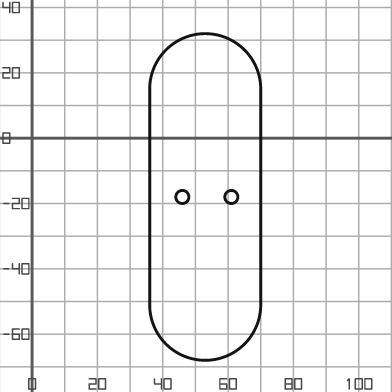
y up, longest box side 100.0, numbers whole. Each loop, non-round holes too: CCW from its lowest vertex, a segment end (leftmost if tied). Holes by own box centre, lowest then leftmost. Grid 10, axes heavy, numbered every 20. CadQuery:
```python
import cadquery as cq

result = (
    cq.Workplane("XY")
    .moveTo(36.0, -51.0)
    .threePointArc((53.0, -68.0), (70.0, -51.0))
    .lineTo(70.0, 15.0)
    .threePointArc((53.0, 32.0), (36.0, 15.0))
    .close()
    .moveTo(46.0, -18.0)
    .circle(2.0)
    .moveTo(61.0, -18.0)
    .circle(2.0)
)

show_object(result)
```